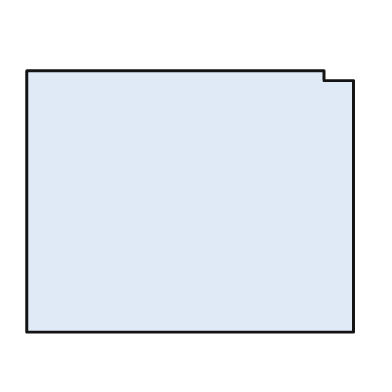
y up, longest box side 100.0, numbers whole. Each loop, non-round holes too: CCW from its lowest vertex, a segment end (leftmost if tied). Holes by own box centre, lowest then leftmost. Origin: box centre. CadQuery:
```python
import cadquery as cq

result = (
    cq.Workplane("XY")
    .moveTo(-50.0, -40.0)
    .lineTo(50.0, -40.0)
    .lineTo(50.0, 37.0)
    .lineTo(41.0, 37.0)
    .lineTo(41.0, 40.0)
    .lineTo(-50.0, 40.0)
    .close()
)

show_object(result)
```